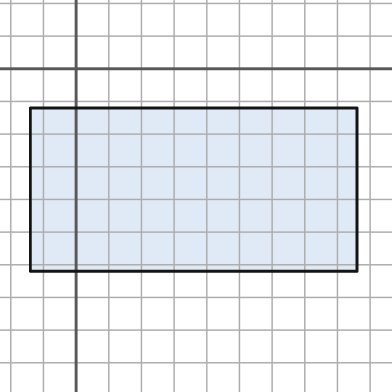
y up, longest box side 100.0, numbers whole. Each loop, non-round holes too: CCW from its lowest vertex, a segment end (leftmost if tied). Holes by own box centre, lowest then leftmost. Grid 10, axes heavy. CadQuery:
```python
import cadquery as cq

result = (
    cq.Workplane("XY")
    .moveTo(-14.0, -62.0)
    .lineTo(86.0, -62.0)
    .lineTo(86.0, -12.0)
    .lineTo(-14.0, -12.0)
    .close()
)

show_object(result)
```